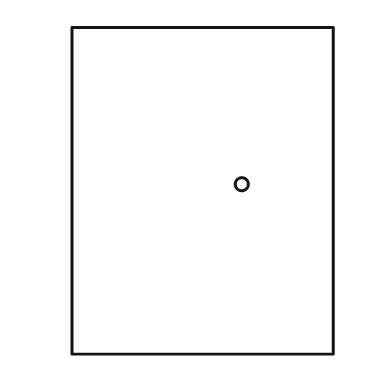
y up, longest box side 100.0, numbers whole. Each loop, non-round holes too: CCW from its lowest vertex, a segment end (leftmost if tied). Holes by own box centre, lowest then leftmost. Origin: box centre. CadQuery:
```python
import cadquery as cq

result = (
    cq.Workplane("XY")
    .moveTo(-40.0, -50.0)
    .lineTo(40.0, -50.0)
    .lineTo(40.0, 50.0)
    .lineTo(-40.0, 50.0)
    .close()
    .moveTo(12.0, 2.0)
    .circle(2.0)
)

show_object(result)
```